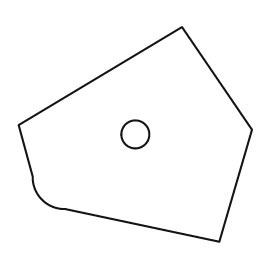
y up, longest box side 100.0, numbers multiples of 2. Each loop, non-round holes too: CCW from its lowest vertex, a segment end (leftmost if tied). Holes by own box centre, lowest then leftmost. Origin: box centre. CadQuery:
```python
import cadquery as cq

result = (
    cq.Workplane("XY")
    .moveTo(36.0, -46.0)
    .lineTo(50.0, 2.0)
    .lineTo(20.0, 46.0)
    .lineTo(-50.0, 4.0)
    .lineTo(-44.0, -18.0)
    .threePointArc((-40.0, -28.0), (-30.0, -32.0))
    .close()
    .moveTo(0.0, 0.0)
    .circle(6.0)
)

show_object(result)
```